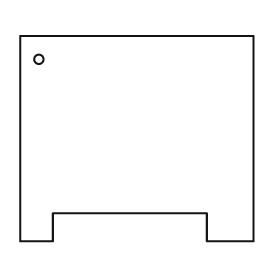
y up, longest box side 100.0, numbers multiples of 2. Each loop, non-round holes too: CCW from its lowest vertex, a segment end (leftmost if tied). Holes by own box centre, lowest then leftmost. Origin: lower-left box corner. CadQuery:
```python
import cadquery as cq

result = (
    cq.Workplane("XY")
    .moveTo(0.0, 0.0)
    .lineTo(14.0, 0.0)
    .lineTo(14.0, 12.0)
    .lineTo(80.0, 12.0)
    .lineTo(80.0, 0.0)
    .lineTo(100.0, 0.0)
    .lineTo(100.0, 88.0)
    .lineTo(0.0, 88.0)
    .close()
    .moveTo(8.0, 78.0)
    .circle(2.0)
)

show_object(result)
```